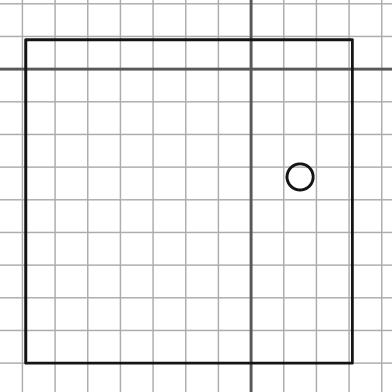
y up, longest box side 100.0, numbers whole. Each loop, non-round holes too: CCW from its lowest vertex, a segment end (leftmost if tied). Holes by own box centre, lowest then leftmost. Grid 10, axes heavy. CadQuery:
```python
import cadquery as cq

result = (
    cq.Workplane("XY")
    .moveTo(-69.0, -90.0)
    .lineTo(31.0, -90.0)
    .lineTo(31.0, 9.0)
    .lineTo(-69.0, 9.0)
    .close()
    .moveTo(15.0, -33.0)
    .circle(4.0)
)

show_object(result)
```